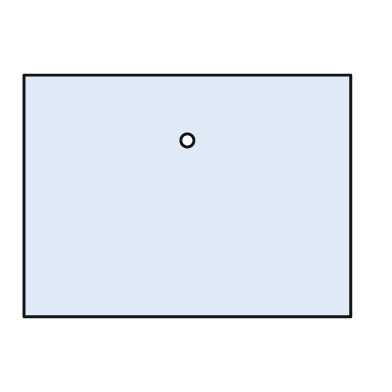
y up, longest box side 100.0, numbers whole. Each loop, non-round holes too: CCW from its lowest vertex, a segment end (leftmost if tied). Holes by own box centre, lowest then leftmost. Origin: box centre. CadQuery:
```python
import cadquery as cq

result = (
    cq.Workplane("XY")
    .moveTo(-50.0, -37.0)
    .lineTo(50.0, -37.0)
    .lineTo(50.0, 37.0)
    .lineTo(-50.0, 37.0)
    .close()
    .moveTo(0.0, 17.0)
    .circle(2.0)
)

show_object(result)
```